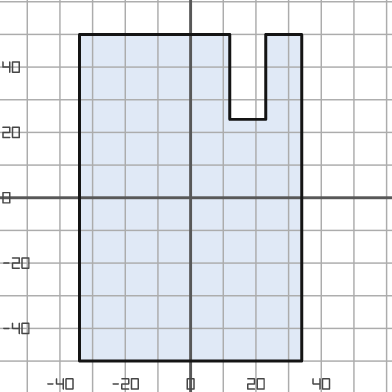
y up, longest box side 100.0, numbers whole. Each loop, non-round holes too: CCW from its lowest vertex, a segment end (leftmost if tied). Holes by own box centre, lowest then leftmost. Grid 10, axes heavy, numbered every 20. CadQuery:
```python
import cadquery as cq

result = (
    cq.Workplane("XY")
    .moveTo(-34.0, -50.0)
    .lineTo(34.0, -50.0)
    .lineTo(34.0, 50.0)
    .lineTo(23.0, 50.0)
    .lineTo(23.0, 24.0)
    .lineTo(12.0, 24.0)
    .lineTo(12.0, 50.0)
    .lineTo(-34.0, 50.0)
    .close()
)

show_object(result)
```